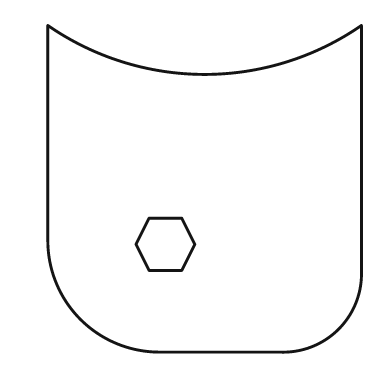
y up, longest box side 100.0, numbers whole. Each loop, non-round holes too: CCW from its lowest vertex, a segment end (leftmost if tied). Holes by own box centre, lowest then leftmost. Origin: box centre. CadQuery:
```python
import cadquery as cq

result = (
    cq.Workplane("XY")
    .moveTo(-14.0, -50.0)
    .lineTo(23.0, -50.0)
    .threePointArc((41.0, -43.0), (48.0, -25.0))
    .lineTo(48.0, 50.0)
    .threePointArc((0.0, 35.0), (-48.0, 50.0))
    .lineTo(-48.0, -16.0)
    .threePointArc((-38.0, -40.0), (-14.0, -50.0))
    .close()
    .moveTo(-17.0, -25.0)
    .lineTo(-7.0, -25.0)
    .lineTo(-3.0, -17.0)
    .lineTo(-7.0, -9.0)
    .lineTo(-17.0, -9.0)
    .lineTo(-21.0, -17.0)
    .close()
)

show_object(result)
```